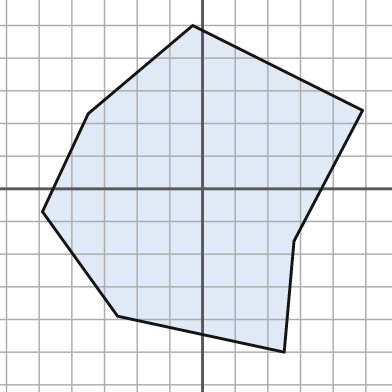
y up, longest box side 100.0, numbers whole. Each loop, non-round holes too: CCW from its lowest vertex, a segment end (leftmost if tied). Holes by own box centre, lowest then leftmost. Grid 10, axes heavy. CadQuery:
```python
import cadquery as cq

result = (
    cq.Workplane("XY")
    .moveTo(25.0, -50.0)
    .lineTo(28.0, -16.0)
    .lineTo(49.0, 24.0)
    .lineTo(-3.0, 50.0)
    .lineTo(-35.0, 23.0)
    .lineTo(-49.0, -7.0)
    .lineTo(-26.0, -39.0)
    .close()
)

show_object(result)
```